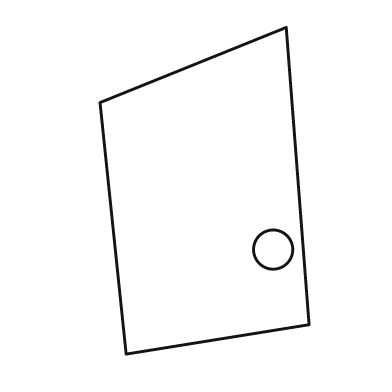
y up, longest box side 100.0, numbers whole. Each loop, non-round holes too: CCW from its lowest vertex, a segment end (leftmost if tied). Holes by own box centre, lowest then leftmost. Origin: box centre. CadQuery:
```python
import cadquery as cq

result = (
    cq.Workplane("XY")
    .moveTo(-24.0, -50.0)
    .lineTo(32.0, -41.0)
    .lineTo(25.0, 50.0)
    .lineTo(-32.0, 27.0)
    .close()
    .moveTo(21.0, -18.0)
    .circle(6.0)
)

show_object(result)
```